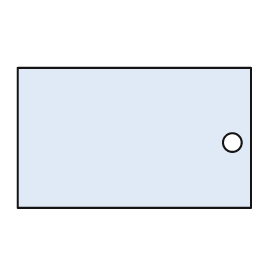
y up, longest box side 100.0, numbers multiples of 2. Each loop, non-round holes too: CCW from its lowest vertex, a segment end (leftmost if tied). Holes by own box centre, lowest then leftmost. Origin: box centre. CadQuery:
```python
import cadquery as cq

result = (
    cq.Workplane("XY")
    .moveTo(-50.0, -30.0)
    .lineTo(50.0, -30.0)
    .lineTo(50.0, 30.0)
    .lineTo(-50.0, 30.0)
    .close()
    .moveTo(42.0, -2.0)
    .circle(4.0)
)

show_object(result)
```